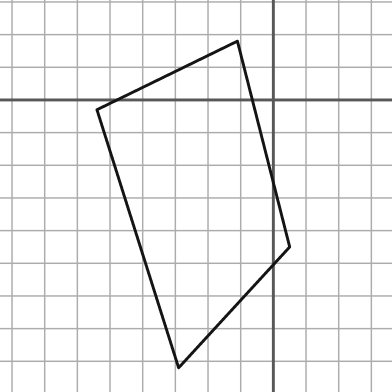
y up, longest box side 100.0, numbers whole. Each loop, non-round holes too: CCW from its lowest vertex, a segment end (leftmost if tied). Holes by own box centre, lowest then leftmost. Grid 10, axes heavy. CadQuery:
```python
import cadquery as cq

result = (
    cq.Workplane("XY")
    .moveTo(-29.0, -82.0)
    .lineTo(5.0, -45.0)
    .lineTo(-11.0, 18.0)
    .lineTo(-54.0, -3.0)
    .close()
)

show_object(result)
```